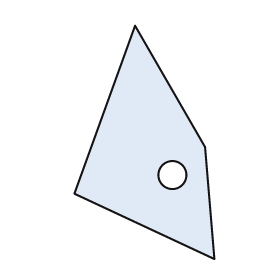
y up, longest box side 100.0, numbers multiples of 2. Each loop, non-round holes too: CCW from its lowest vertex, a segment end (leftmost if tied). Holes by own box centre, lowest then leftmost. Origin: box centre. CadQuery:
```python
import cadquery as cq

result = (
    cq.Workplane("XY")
    .moveTo(30.0, -50.0)
    .lineTo(26.0, -2.0)
    .lineTo(-4.0, 50.0)
    .lineTo(-30.0, -22.0)
    .close()
    .moveTo(12.0, -14.0)
    .circle(6.0)
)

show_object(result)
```